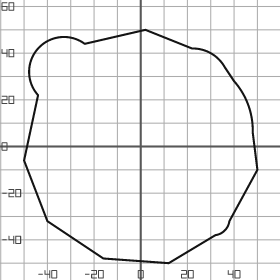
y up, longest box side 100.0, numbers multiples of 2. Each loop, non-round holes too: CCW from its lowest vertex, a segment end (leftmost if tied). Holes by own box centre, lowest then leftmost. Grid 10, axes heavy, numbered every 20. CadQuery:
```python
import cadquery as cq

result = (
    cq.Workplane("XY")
    .moveTo(12.0, -50.0)
    .lineTo(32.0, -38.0)
    .threePointArc((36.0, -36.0), (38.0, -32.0))
    .lineTo(50.0, -10.0)
    .lineTo(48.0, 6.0)
    .threePointArc((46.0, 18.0), (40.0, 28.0))
    .lineTo(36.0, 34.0)
    .threePointArc((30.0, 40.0), (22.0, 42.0))
    .lineTo(2.0, 50.0)
    .lineTo(-24.0, 44.0)
    .threePointArc((-44.0, 42.0), (-44.0, 22.0))
    .lineTo(-50.0, -6.0)
    .lineTo(-40.0, -32.0)
    .lineTo(-16.0, -48.0)
    .close()
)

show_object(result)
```